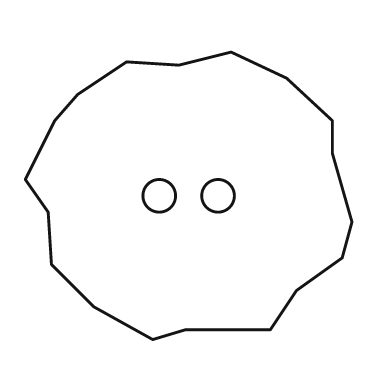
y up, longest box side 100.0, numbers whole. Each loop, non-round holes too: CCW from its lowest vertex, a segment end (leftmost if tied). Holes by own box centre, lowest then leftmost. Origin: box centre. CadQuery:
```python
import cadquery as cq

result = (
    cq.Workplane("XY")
    .moveTo(-11.0, -44.0)
    .lineTo(-1.0, -41.0)
    .lineTo(25.0, -41.0)
    .lineTo(33.0, -29.0)
    .lineTo(47.0, -19.0)
    .lineTo(50.0, -8.0)
    .lineTo(44.0, 13.0)
    .lineTo(44.0, 23.0)
    .lineTo(30.0, 36.0)
    .lineTo(13.0, 44.0)
    .lineTo(-3.0, 40.0)
    .lineTo(-19.0, 41.0)
    .lineTo(-34.0, 31.0)
    .lineTo(-41.0, 23.0)
    .lineTo(-50.0, 5.0)
    .lineTo(-43.0, -5.0)
    .lineTo(-42.0, -21.0)
    .lineTo(-29.0, -34.0)
    .close()
    .moveTo(-9.0, 0.0)
    .circle(5.0)
    .moveTo(9.0, 0.0)
    .circle(5.0)
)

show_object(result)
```